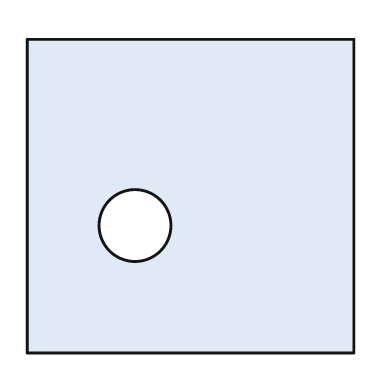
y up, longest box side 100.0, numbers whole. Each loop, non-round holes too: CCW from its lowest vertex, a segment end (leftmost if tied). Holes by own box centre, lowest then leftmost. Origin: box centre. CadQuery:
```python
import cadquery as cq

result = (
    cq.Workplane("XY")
    .moveTo(-50.0, -48.0)
    .lineTo(50.0, -48.0)
    .lineTo(50.0, 48.0)
    .lineTo(-50.0, 48.0)
    .close()
    .moveTo(-17.0, -9.0)
    .circle(11.0)
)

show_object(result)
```